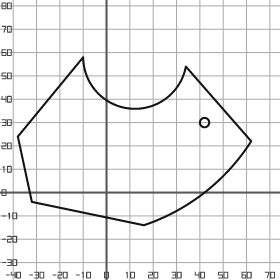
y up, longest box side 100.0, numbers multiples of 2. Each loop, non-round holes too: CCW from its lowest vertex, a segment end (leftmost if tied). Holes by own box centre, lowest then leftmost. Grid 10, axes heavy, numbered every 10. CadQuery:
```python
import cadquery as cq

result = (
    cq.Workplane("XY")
    .moveTo(16.0, -14.0)
    .threePointArc((42.0, 0.0), (62.0, 22.0))
    .lineTo(34.0, 54.0)
    .threePointArc((10.0, 36.0), (-10.0, 58.0))
    .lineTo(-38.0, 24.0)
    .lineTo(-32.0, -4.0)
    .close()
    .moveTo(42.0, 30.0)
    .circle(2.0)
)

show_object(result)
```